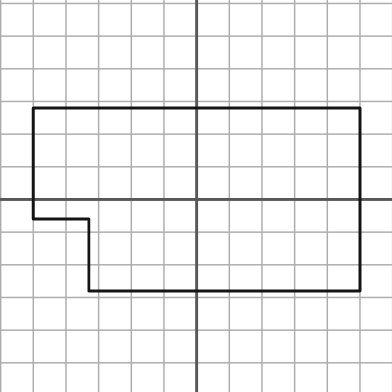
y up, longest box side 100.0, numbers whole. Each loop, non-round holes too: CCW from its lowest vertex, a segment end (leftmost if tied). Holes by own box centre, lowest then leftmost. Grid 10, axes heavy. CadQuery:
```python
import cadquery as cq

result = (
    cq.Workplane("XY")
    .moveTo(-33.0, -28.0)
    .lineTo(50.0, -28.0)
    .lineTo(50.0, 28.0)
    .lineTo(-50.0, 28.0)
    .lineTo(-50.0, -6.0)
    .lineTo(-33.0, -6.0)
    .close()
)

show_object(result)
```